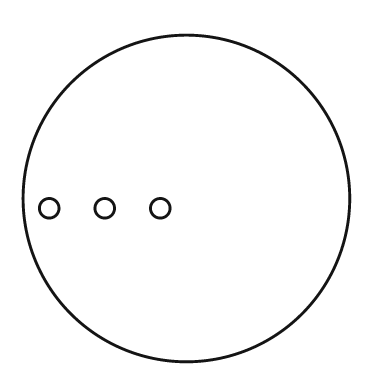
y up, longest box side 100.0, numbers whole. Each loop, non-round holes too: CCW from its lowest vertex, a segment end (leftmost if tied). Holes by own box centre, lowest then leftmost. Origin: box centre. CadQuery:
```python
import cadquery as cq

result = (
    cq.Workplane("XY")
    .moveTo(0.0, 0.0)
    .circle(50.0)
    .moveTo(-42.0, -3.0)
    .circle(3.0)
    .moveTo(-25.0, -3.0)
    .circle(3.0)
    .moveTo(-8.0, -3.0)
    .circle(3.0)
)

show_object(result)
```